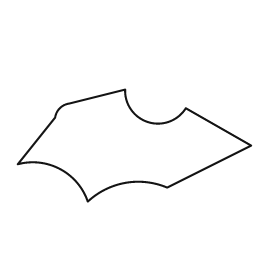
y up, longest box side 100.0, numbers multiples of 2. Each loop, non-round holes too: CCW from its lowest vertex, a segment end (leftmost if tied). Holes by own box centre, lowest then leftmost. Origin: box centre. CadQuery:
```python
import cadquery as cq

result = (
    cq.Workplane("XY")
    .moveTo(-20.0, -24.0)
    .threePointArc((-4.0, -16.0), (14.0, -18.0))
    .lineTo(50.0, 0.0)
    .lineTo(22.0, 16.0)
    .threePointArc((6.0, 10.0), (-4.0, 24.0))
    .lineTo(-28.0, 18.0)
    .threePointArc((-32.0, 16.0), (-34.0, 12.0))
    .lineTo(-50.0, -8.0)
    .threePointArc((-32.0, -10.0), (-20.0, -24.0))
    .close()
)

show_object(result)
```